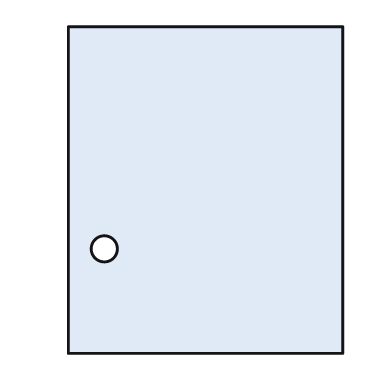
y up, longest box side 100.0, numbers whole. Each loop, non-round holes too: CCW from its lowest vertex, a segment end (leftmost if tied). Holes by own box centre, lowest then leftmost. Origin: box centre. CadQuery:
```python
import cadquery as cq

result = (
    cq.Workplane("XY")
    .moveTo(-42.0, -50.0)
    .lineTo(42.0, -50.0)
    .lineTo(42.0, 50.0)
    .lineTo(-42.0, 50.0)
    .close()
    .moveTo(-31.0, -18.0)
    .circle(4.0)
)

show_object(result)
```